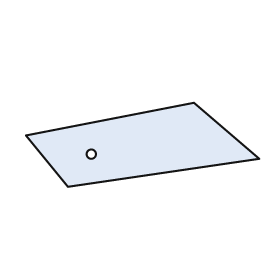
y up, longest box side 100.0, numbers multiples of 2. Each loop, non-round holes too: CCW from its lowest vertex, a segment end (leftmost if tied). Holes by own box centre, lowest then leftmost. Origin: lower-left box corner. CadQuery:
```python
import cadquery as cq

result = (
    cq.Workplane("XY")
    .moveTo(18.0, 0.0)
    .lineTo(100.0, 12.0)
    .lineTo(72.0, 36.0)
    .lineTo(0.0, 22.0)
    .close()
    .moveTo(28.0, 14.0)
    .circle(2.0)
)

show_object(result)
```